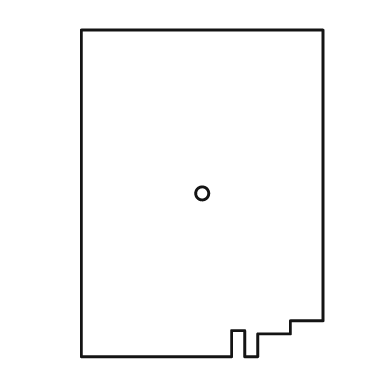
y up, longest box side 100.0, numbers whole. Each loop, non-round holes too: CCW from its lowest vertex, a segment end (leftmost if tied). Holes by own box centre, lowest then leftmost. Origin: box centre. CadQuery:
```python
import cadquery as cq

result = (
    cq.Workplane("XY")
    .moveTo(-37.0, -50.0)
    .lineTo(9.0, -50.0)
    .lineTo(9.0, -42.0)
    .lineTo(13.0, -42.0)
    .lineTo(13.0, -50.0)
    .lineTo(17.0, -50.0)
    .lineTo(17.0, -43.0)
    .lineTo(27.0, -43.0)
    .lineTo(27.0, -39.0)
    .lineTo(37.0, -39.0)
    .lineTo(37.0, 50.0)
    .lineTo(-37.0, 50.0)
    .close()
    .moveTo(0.0, 0.0)
    .circle(2.0)
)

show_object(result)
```